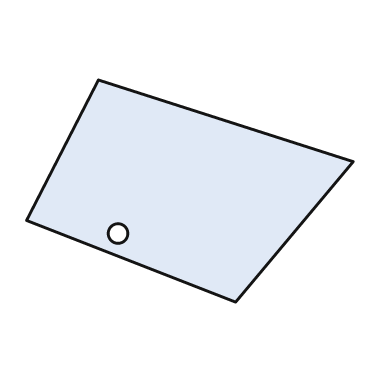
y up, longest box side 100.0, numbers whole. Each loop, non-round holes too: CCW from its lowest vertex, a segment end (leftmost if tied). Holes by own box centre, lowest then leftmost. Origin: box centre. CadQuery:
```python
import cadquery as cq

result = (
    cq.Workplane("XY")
    .moveTo(14.0, -34.0)
    .lineTo(50.0, 9.0)
    .lineTo(-28.0, 34.0)
    .lineTo(-50.0, -9.0)
    .close()
    .moveTo(-22.0, -13.0)
    .circle(3.0)
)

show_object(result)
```